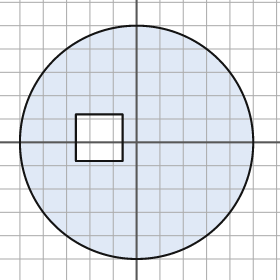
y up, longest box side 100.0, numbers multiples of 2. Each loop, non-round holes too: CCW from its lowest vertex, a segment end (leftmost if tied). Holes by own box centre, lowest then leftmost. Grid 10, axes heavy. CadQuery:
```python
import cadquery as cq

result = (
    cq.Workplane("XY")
    .moveTo(0.0, 0.0)
    .circle(50.0)
    .moveTo(-26.0, -8.0)
    .lineTo(-6.0, -8.0)
    .lineTo(-6.0, 12.0)
    .lineTo(-26.0, 12.0)
    .close()
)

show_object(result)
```